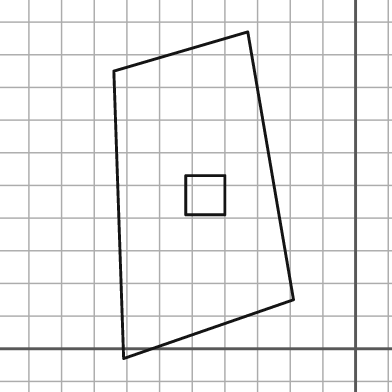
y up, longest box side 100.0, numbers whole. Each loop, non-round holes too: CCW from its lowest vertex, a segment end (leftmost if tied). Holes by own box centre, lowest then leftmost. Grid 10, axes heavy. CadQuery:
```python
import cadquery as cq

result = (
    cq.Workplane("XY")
    .moveTo(-71.0, -3.0)
    .lineTo(-19.0, 15.0)
    .lineTo(-33.0, 97.0)
    .lineTo(-74.0, 85.0)
    .close()
    .moveTo(-52.0, 41.0)
    .lineTo(-40.0, 41.0)
    .lineTo(-40.0, 53.0)
    .lineTo(-52.0, 53.0)
    .close()
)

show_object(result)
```